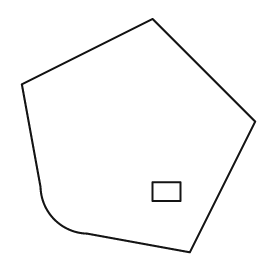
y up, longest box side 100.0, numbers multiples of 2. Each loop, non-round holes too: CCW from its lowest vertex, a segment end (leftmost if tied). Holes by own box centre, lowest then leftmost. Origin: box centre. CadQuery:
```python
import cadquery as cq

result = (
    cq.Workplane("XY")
    .moveTo(22.0, -50.0)
    .lineTo(50.0, 6.0)
    .lineTo(6.0, 50.0)
    .lineTo(-50.0, 22.0)
    .lineTo(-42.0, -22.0)
    .threePointArc((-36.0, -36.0), (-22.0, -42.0))
    .close()
    .moveTo(6.0, -28.0)
    .lineTo(18.0, -28.0)
    .lineTo(18.0, -20.0)
    .lineTo(6.0, -20.0)
    .close()
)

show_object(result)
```